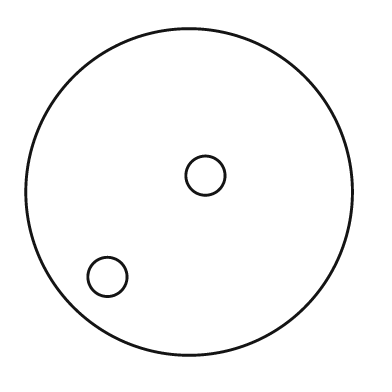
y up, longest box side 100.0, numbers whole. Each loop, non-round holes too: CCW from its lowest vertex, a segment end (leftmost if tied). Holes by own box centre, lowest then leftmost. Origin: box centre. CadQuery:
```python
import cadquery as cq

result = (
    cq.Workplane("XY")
    .moveTo(0.0, 0.0)
    .circle(50.0)
    .moveTo(-25.0, -26.0)
    .circle(6.0)
    .moveTo(5.0, 5.0)
    .circle(6.0)
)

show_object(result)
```